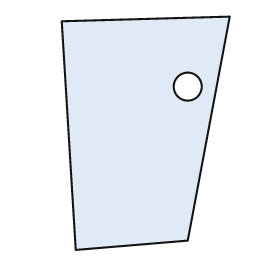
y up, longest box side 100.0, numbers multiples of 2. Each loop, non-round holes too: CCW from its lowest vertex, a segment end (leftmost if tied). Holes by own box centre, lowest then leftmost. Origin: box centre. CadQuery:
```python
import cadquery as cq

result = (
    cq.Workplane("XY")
    .moveTo(-30.0, -50.0)
    .lineTo(18.0, -46.0)
    .lineTo(36.0, 50.0)
    .lineTo(-36.0, 48.0)
    .close()
    .moveTo(18.0, 20.0)
    .circle(6.0)
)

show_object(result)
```